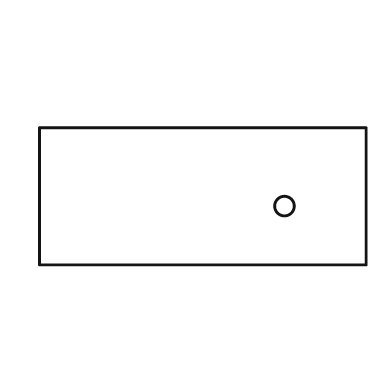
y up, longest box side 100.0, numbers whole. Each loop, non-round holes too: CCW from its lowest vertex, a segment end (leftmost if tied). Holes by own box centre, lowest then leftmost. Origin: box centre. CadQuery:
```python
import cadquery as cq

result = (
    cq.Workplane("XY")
    .moveTo(-50.0, -21.0)
    .lineTo(50.0, -21.0)
    .lineTo(50.0, 21.0)
    .lineTo(-50.0, 21.0)
    .close()
    .moveTo(25.0, -3.0)
    .circle(3.0)
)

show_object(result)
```